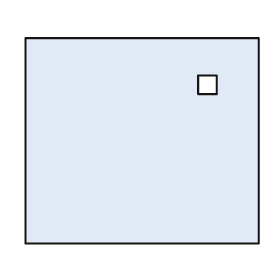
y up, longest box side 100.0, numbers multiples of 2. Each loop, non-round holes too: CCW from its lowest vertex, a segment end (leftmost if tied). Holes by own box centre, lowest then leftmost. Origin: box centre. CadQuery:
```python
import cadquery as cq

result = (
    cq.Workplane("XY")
    .moveTo(-50.0, -44.0)
    .lineTo(50.0, -44.0)
    .lineTo(50.0, 44.0)
    .lineTo(-50.0, 44.0)
    .close()
    .moveTo(24.0, 20.0)
    .lineTo(32.0, 20.0)
    .lineTo(32.0, 28.0)
    .lineTo(24.0, 28.0)
    .close()
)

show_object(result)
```